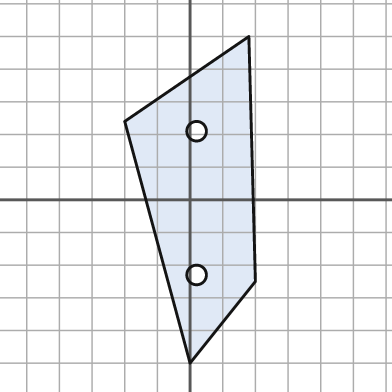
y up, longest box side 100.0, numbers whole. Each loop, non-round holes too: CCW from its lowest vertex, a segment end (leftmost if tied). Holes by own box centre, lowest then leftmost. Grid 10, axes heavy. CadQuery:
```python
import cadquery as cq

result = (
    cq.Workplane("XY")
    .moveTo(0.0, -50.0)
    .lineTo(20.0, -25.0)
    .lineTo(18.0, 50.0)
    .lineTo(-20.0, 24.0)
    .close()
    .moveTo(2.0, -23.0)
    .circle(3.0)
    .moveTo(2.0, 21.0)
    .circle(3.0)
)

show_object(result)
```